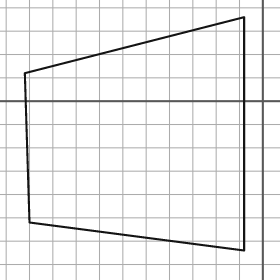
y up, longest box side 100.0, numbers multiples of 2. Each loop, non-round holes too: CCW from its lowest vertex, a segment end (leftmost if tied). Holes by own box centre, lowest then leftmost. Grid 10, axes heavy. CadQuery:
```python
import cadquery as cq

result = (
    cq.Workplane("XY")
    .moveTo(-8.0, -64.0)
    .lineTo(-8.0, 36.0)
    .lineTo(-102.0, 12.0)
    .lineTo(-100.0, -52.0)
    .close()
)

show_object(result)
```